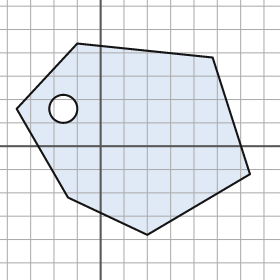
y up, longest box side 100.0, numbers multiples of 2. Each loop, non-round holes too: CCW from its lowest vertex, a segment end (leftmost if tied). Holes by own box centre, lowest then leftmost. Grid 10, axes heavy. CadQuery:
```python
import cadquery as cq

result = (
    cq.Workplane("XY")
    .moveTo(20.0, -38.0)
    .lineTo(64.0, -12.0)
    .lineTo(48.0, 38.0)
    .lineTo(-10.0, 44.0)
    .lineTo(-36.0, 16.0)
    .lineTo(-14.0, -22.0)
    .close()
    .moveTo(-16.0, 16.0)
    .circle(6.0)
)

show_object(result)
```